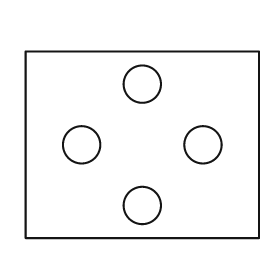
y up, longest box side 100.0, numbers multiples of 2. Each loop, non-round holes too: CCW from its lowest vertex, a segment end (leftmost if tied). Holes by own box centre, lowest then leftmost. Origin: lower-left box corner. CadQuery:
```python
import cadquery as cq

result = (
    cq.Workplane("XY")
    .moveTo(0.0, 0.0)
    .lineTo(100.0, 0.0)
    .lineTo(100.0, 80.0)
    .lineTo(0.0, 80.0)
    .close()
    .moveTo(50.0, 14.0)
    .circle(8.0)
    .moveTo(24.0, 40.0)
    .circle(8.0)
    .moveTo(76.0, 40.0)
    .circle(8.0)
    .moveTo(50.0, 66.0)
    .circle(8.0)
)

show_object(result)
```